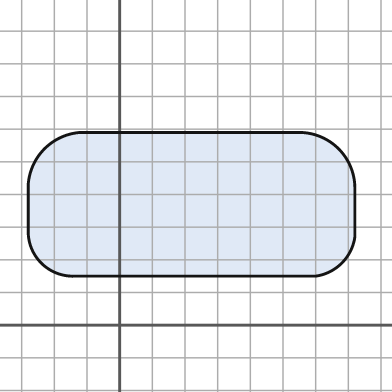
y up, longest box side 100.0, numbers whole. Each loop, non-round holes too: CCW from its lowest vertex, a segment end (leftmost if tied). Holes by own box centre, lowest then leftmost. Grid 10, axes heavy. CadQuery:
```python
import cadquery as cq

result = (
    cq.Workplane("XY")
    .moveTo(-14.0, 15.0)
    .lineTo(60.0, 15.0)
    .threePointArc((68.0, 19.0), (72.0, 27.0))
    .lineTo(72.0, 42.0)
    .threePointArc((67.0, 54.0), (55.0, 59.0))
    .lineTo(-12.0, 59.0)
    .threePointArc((-23.0, 54.0), (-28.0, 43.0))
    .lineTo(-28.0, 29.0)
    .threePointArc((-24.0, 19.0), (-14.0, 15.0))
    .close()
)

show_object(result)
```